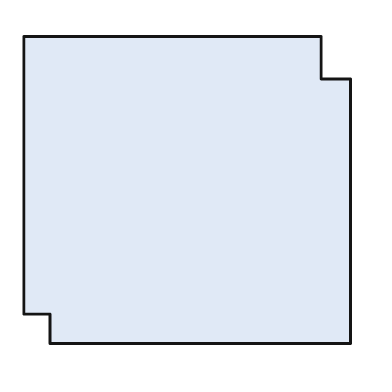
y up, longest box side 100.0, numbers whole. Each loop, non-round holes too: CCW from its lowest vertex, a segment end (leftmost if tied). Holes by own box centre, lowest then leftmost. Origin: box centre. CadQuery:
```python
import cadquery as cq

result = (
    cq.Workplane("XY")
    .moveTo(-42.0, -47.0)
    .lineTo(50.0, -47.0)
    .lineTo(50.0, 34.0)
    .lineTo(41.0, 34.0)
    .lineTo(41.0, 47.0)
    .lineTo(-50.0, 47.0)
    .lineTo(-50.0, -38.0)
    .lineTo(-42.0, -38.0)
    .close()
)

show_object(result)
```